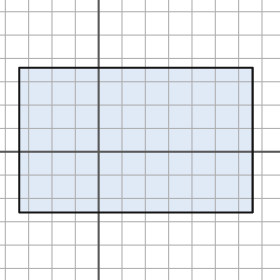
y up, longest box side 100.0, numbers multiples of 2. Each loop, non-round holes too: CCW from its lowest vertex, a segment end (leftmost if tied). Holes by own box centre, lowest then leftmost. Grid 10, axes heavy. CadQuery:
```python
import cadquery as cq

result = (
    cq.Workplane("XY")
    .moveTo(-34.0, -26.0)
    .lineTo(66.0, -26.0)
    .lineTo(66.0, 36.0)
    .lineTo(-34.0, 36.0)
    .close()
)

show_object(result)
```